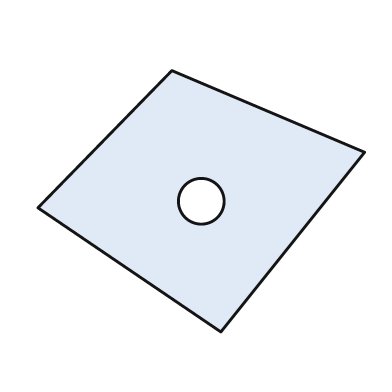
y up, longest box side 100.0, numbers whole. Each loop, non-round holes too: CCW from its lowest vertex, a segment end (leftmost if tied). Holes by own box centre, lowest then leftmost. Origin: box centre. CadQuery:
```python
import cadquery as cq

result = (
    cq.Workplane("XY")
    .moveTo(6.0, -40.0)
    .lineTo(50.0, 15.0)
    .lineTo(-9.0, 40.0)
    .lineTo(-50.0, -2.0)
    .close()
    .moveTo(0.0, 0.0)
    .circle(7.0)
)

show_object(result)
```